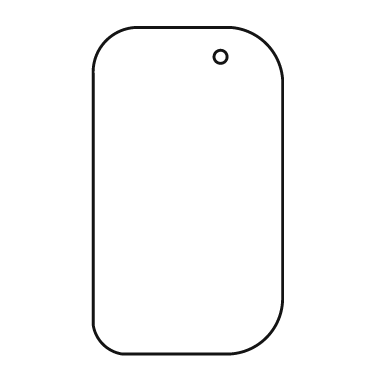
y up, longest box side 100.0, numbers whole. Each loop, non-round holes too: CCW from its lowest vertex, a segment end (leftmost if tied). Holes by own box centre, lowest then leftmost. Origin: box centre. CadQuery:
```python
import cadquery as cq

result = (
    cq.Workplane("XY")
    .moveTo(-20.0, -50.0)
    .lineTo(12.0, -50.0)
    .threePointArc((24.0, -45.0), (29.0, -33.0))
    .lineTo(29.0, 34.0)
    .threePointArc((24.0, 45.0), (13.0, 50.0))
    .lineTo(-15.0, 50.0)
    .threePointArc((-25.0, 46.0), (-29.0, 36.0))
    .lineTo(-29.0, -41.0)
    .threePointArc((-26.0, -47.0), (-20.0, -50.0))
    .close()
    .moveTo(10.0, 41.0)
    .circle(2.0)
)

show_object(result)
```